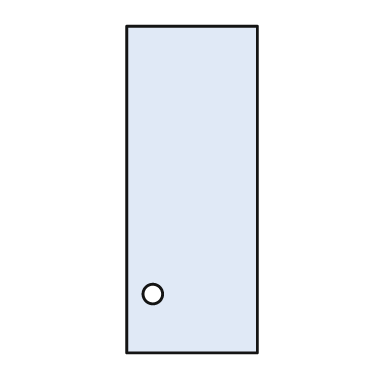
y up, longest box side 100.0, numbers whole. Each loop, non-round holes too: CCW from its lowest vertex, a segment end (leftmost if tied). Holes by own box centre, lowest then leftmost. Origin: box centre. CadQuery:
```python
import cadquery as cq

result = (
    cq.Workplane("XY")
    .moveTo(-20.0, -50.0)
    .lineTo(20.0, -50.0)
    .lineTo(20.0, 50.0)
    .lineTo(-20.0, 50.0)
    .close()
    .moveTo(-12.0, -32.0)
    .circle(3.0)
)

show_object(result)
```